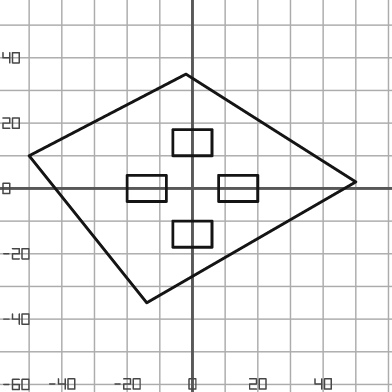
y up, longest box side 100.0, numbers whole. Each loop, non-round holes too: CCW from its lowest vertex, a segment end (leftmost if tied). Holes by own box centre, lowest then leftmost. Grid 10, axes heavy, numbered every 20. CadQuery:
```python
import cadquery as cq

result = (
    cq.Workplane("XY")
    .moveTo(-14.0, -35.0)
    .lineTo(50.0, 2.0)
    .lineTo(-2.0, 35.0)
    .lineTo(-50.0, 10.0)
    .close()
    .moveTo(-6.0, -18.0)
    .lineTo(6.0, -18.0)
    .lineTo(6.0, -10.0)
    .lineTo(-6.0, -10.0)
    .close()
    .moveTo(-20.0, -4.0)
    .lineTo(-8.0, -4.0)
    .lineTo(-8.0, 4.0)
    .lineTo(-20.0, 4.0)
    .close()
    .moveTo(8.0, -4.0)
    .lineTo(20.0, -4.0)
    .lineTo(20.0, 4.0)
    .lineTo(8.0, 4.0)
    .close()
    .moveTo(-6.0, 10.0)
    .lineTo(6.0, 10.0)
    .lineTo(6.0, 18.0)
    .lineTo(-6.0, 18.0)
    .close()
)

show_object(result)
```